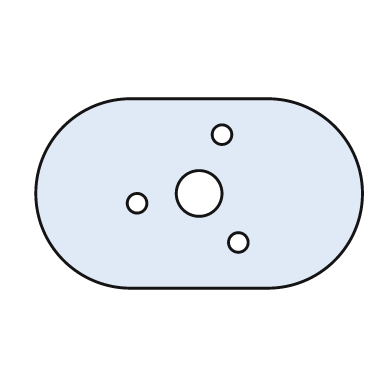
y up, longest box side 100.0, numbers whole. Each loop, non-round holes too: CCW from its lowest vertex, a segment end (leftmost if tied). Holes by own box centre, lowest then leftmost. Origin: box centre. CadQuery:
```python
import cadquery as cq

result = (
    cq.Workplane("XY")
    .moveTo(-21.0, -29.0)
    .lineTo(21.0, -29.0)
    .threePointArc((50.0, 0.0), (21.0, 29.0))
    .lineTo(-21.0, 29.0)
    .threePointArc((-50.0, 0.0), (-21.0, -29.0))
    .close()
    .moveTo(12.0, -15.0)
    .circle(3.0)
    .moveTo(-19.0, -3.0)
    .circle(3.0)
    .moveTo(0.0, 0.0)
    .circle(7.0)
    .moveTo(7.0, 18.0)
    .circle(3.0)
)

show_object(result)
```